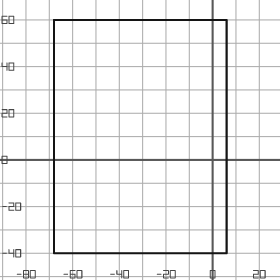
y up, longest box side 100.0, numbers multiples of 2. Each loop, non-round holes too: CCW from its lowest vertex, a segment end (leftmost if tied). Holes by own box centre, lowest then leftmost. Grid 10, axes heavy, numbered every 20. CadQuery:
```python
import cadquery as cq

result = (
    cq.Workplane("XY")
    .moveTo(-68.0, -40.0)
    .lineTo(6.0, -40.0)
    .lineTo(6.0, 60.0)
    .lineTo(-68.0, 60.0)
    .close()
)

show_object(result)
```